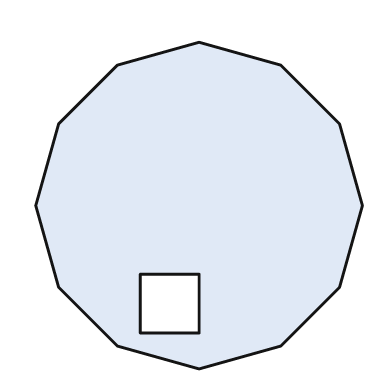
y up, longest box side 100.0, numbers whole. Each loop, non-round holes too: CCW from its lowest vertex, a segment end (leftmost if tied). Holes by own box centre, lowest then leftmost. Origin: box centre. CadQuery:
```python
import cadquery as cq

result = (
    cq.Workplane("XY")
    .moveTo(0.0, -50.0)
    .lineTo(25.0, -43.0)
    .lineTo(43.0, -25.0)
    .lineTo(50.0, 0.0)
    .lineTo(43.0, 25.0)
    .lineTo(25.0, 43.0)
    .lineTo(0.0, 50.0)
    .lineTo(-25.0, 43.0)
    .lineTo(-43.0, 25.0)
    .lineTo(-50.0, 0.0)
    .lineTo(-43.0, -25.0)
    .lineTo(-25.0, -43.0)
    .close()
    .moveTo(-18.0, -39.0)
    .lineTo(0.0, -39.0)
    .lineTo(0.0, -21.0)
    .lineTo(-18.0, -21.0)
    .close()
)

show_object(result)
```